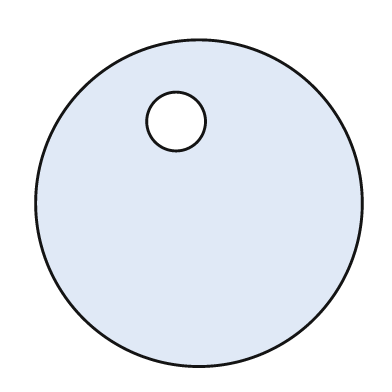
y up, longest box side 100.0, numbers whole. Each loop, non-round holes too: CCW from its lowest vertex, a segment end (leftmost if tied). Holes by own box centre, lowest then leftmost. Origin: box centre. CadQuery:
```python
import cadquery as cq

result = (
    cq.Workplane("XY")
    .moveTo(0.0, 0.0)
    .circle(50.0)
    .moveTo(-7.0, 25.0)
    .circle(9.0)
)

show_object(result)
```